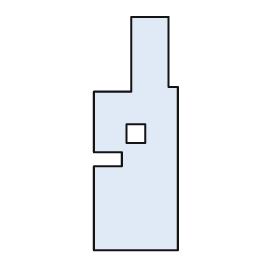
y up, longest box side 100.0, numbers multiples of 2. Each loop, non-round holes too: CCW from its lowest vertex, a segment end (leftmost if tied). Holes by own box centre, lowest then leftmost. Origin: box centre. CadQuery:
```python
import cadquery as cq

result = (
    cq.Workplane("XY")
    .moveTo(-18.0, -50.0)
    .lineTo(18.0, -50.0)
    .lineTo(18.0, 20.0)
    .lineTo(14.0, 20.0)
    .lineTo(14.0, 50.0)
    .lineTo(-2.0, 50.0)
    .lineTo(-2.0, 18.0)
    .lineTo(-18.0, 18.0)
    .lineTo(-18.0, -8.0)
    .lineTo(-6.0, -8.0)
    .lineTo(-6.0, -14.0)
    .lineTo(-18.0, -14.0)
    .close()
    .moveTo(-4.0, -4.0)
    .lineTo(4.0, -4.0)
    .lineTo(4.0, 4.0)
    .lineTo(-4.0, 4.0)
    .close()
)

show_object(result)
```